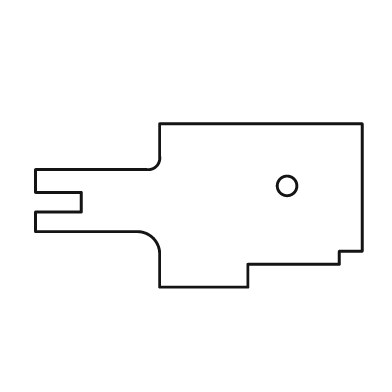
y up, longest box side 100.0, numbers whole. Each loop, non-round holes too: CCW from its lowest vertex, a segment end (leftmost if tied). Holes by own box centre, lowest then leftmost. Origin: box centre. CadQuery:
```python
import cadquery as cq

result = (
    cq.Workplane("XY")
    .moveTo(-12.0, -25.0)
    .lineTo(15.0, -25.0)
    .lineTo(15.0, -18.0)
    .lineTo(43.0, -18.0)
    .lineTo(43.0, -14.0)
    .lineTo(50.0, -14.0)
    .lineTo(50.0, 25.0)
    .lineTo(-12.0, 25.0)
    .lineTo(-12.0, 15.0)
    .threePointArc((-13.0, 12.0), (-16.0, 11.0))
    .lineTo(-50.0, 11.0)
    .lineTo(-50.0, 4.0)
    .lineTo(-36.0, 4.0)
    .lineTo(-36.0, -2.0)
    .lineTo(-50.0, -2.0)
    .lineTo(-50.0, -8.0)
    .lineTo(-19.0, -8.0)
    .threePointArc((-14.0, -10.0), (-12.0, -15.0))
    .close()
    .moveTo(27.0, 6.0)
    .circle(3.0)
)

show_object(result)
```